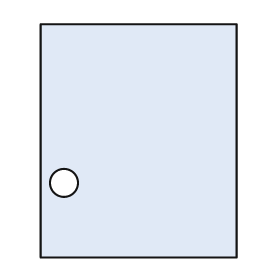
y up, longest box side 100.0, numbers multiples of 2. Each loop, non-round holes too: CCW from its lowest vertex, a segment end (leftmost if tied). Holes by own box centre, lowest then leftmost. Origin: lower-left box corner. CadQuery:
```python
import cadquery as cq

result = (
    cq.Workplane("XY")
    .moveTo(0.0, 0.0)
    .lineTo(84.0, 0.0)
    .lineTo(84.0, 100.0)
    .lineTo(0.0, 100.0)
    .close()
    .moveTo(10.0, 32.0)
    .circle(6.0)
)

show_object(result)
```